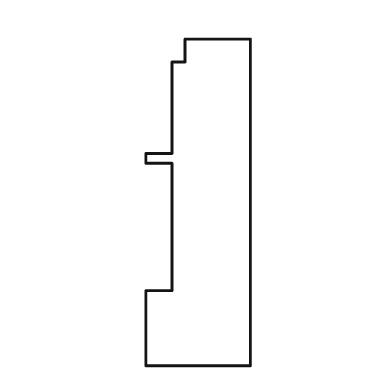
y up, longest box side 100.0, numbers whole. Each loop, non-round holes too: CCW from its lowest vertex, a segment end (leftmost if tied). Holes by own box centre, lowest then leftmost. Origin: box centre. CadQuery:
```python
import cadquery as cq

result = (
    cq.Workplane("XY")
    .moveTo(-16.0, -50.0)
    .lineTo(16.0, -50.0)
    .lineTo(16.0, 50.0)
    .lineTo(-4.0, 50.0)
    .lineTo(-4.0, 43.0)
    .lineTo(-8.0, 43.0)
    .lineTo(-8.0, 15.0)
    .lineTo(-16.0, 15.0)
    .lineTo(-16.0, 12.0)
    .lineTo(-8.0, 12.0)
    .lineTo(-8.0, -27.0)
    .lineTo(-16.0, -27.0)
    .close()
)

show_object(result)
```